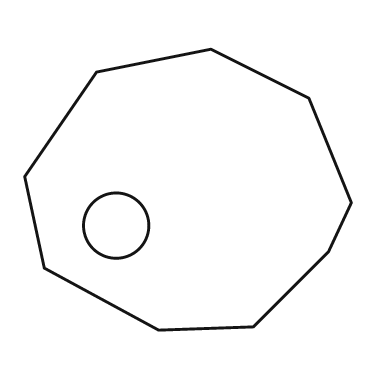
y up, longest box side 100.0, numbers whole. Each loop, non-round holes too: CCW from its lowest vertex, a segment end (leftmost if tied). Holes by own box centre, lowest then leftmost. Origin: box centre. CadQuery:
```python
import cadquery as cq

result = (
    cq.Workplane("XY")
    .moveTo(-9.0, -43.0)
    .lineTo(20.0, -42.0)
    .lineTo(43.0, -19.0)
    .lineTo(50.0, -4.0)
    .lineTo(37.0, 28.0)
    .lineTo(7.0, 43.0)
    .lineTo(-28.0, 36.0)
    .lineTo(-50.0, 4.0)
    .lineTo(-44.0, -24.0)
    .close()
    .moveTo(-22.0, -11.0)
    .circle(10.0)
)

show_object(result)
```